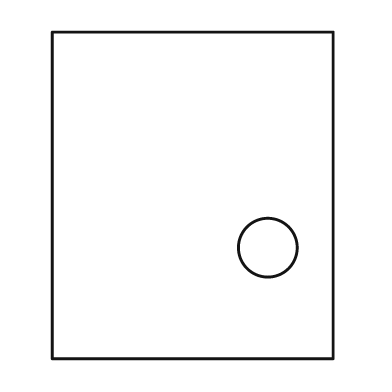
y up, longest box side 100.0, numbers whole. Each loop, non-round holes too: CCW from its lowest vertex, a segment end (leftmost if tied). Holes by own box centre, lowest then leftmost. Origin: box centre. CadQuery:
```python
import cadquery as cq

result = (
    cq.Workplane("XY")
    .moveTo(-43.0, -50.0)
    .lineTo(43.0, -50.0)
    .lineTo(43.0, 50.0)
    .lineTo(-43.0, 50.0)
    .close()
    .moveTo(23.0, -16.0)
    .circle(9.0)
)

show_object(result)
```